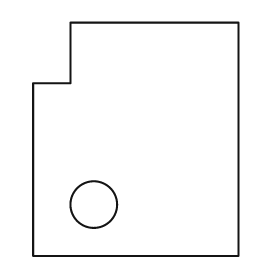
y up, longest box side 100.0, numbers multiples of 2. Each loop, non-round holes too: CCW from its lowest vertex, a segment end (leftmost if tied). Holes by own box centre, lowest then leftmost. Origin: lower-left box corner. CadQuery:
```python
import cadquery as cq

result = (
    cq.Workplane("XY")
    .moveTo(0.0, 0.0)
    .lineTo(88.0, 0.0)
    .lineTo(88.0, 100.0)
    .lineTo(16.0, 100.0)
    .lineTo(16.0, 74.0)
    .lineTo(0.0, 74.0)
    .close()
    .moveTo(26.0, 22.0)
    .circle(10.0)
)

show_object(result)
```